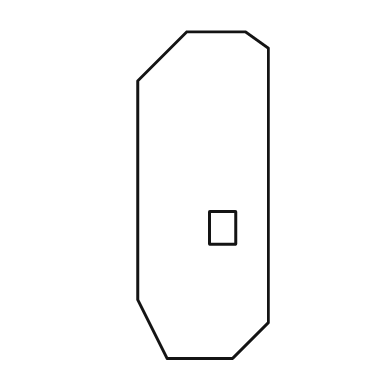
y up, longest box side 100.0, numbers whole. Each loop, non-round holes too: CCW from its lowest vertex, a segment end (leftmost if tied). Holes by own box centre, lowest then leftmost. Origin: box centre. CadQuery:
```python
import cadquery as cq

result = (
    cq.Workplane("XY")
    .moveTo(-11.0, -50.0)
    .lineTo(9.0, -50.0)
    .lineTo(20.0, -39.0)
    .lineTo(20.0, 45.0)
    .lineTo(13.0, 50.0)
    .lineTo(-5.0, 50.0)
    .lineTo(-20.0, 35.0)
    .lineTo(-20.0, -32.0)
    .close()
    .moveTo(2.0, -15.0)
    .lineTo(10.0, -15.0)
    .lineTo(10.0, -5.0)
    .lineTo(2.0, -5.0)
    .close()
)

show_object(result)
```